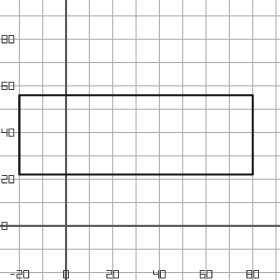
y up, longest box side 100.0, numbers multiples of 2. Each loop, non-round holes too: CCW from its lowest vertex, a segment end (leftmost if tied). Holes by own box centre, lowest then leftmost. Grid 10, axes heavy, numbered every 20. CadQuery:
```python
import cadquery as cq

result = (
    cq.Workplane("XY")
    .moveTo(-20.0, 22.0)
    .lineTo(80.0, 22.0)
    .lineTo(80.0, 56.0)
    .lineTo(-20.0, 56.0)
    .close()
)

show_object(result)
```